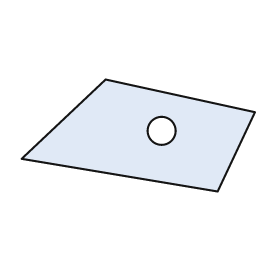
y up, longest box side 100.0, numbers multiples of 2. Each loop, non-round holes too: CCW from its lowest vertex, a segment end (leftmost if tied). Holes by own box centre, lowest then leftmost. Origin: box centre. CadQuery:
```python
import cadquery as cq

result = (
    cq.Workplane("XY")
    .moveTo(34.0, -24.0)
    .lineTo(50.0, 10.0)
    .lineTo(-14.0, 24.0)
    .lineTo(-50.0, -10.0)
    .close()
    .moveTo(10.0, 2.0)
    .circle(6.0)
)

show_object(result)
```